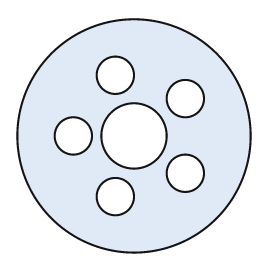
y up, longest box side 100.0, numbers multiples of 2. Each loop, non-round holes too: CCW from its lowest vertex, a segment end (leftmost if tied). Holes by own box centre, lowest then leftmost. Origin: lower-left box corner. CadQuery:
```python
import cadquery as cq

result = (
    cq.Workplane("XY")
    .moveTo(50.0, 50.0)
    .circle(50.0)
    .moveTo(42.0, 24.0)
    .circle(8.0)
    .moveTo(72.0, 34.0)
    .circle(8.0)
    .moveTo(24.0, 50.0)
    .circle(8.0)
    .moveTo(50.0, 50.0)
    .circle(14.0)
    .moveTo(72.0, 66.0)
    .circle(8.0)
    .moveTo(42.0, 76.0)
    .circle(8.0)
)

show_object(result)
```